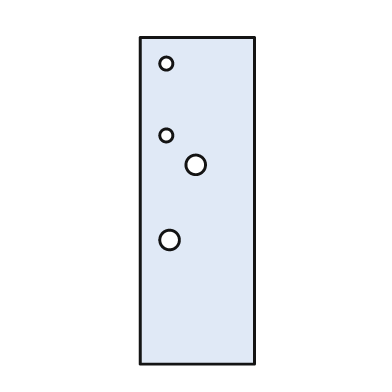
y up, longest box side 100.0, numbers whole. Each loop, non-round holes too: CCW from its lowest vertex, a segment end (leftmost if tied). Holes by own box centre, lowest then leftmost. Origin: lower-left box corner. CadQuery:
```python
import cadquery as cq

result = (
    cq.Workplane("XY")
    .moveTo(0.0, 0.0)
    .lineTo(35.0, 0.0)
    .lineTo(35.0, 100.0)
    .lineTo(0.0, 100.0)
    .close()
    .moveTo(9.0, 38.0)
    .circle(3.0)
    .moveTo(17.0, 61.0)
    .circle(3.0)
    .moveTo(8.0, 70.0)
    .circle(2.0)
    .moveTo(8.0, 92.0)
    .circle(2.0)
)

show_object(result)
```